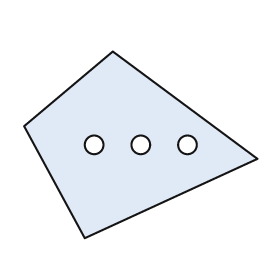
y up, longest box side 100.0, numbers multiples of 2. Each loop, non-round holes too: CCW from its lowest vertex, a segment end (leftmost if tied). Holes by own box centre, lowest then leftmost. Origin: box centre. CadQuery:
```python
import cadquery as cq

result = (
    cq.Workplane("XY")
    .moveTo(-24.0, -40.0)
    .lineTo(50.0, -6.0)
    .lineTo(-12.0, 40.0)
    .lineTo(-50.0, 8.0)
    .close()
    .moveTo(-20.0, 0.0)
    .circle(4.0)
    .moveTo(0.0, 0.0)
    .circle(4.0)
    .moveTo(20.0, 0.0)
    .circle(4.0)
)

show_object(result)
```